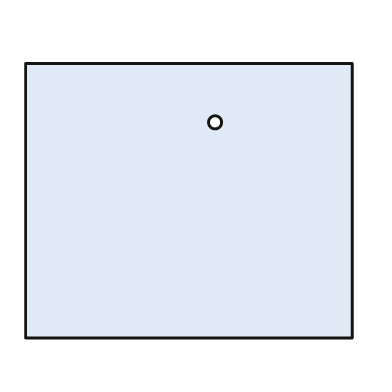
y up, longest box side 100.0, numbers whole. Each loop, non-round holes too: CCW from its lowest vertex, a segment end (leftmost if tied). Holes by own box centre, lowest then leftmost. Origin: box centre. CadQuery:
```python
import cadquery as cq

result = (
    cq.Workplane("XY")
    .moveTo(-50.0, -42.0)
    .lineTo(50.0, -42.0)
    .lineTo(50.0, 42.0)
    .lineTo(-50.0, 42.0)
    .close()
    .moveTo(8.0, 24.0)
    .circle(2.0)
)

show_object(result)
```